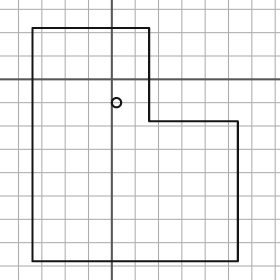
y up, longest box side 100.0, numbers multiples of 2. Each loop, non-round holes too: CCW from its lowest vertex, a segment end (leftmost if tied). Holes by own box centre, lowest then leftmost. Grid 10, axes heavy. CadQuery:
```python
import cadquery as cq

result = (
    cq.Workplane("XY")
    .moveTo(-34.0, -78.0)
    .lineTo(54.0, -78.0)
    .lineTo(54.0, -18.0)
    .lineTo(16.0, -18.0)
    .lineTo(16.0, 22.0)
    .lineTo(-34.0, 22.0)
    .close()
    .moveTo(2.0, -10.0)
    .circle(2.0)
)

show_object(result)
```